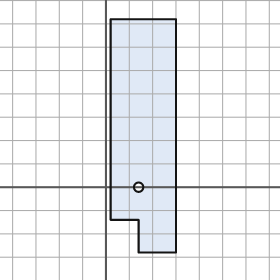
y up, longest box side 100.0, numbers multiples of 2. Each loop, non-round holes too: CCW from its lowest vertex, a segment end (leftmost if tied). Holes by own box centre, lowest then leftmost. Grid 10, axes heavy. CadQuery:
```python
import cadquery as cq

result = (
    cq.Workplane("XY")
    .moveTo(14.0, -28.0)
    .lineTo(30.0, -28.0)
    .lineTo(30.0, 72.0)
    .lineTo(2.0, 72.0)
    .lineTo(2.0, -14.0)
    .lineTo(14.0, -14.0)
    .close()
    .moveTo(14.0, 0.0)
    .circle(2.0)
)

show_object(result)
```